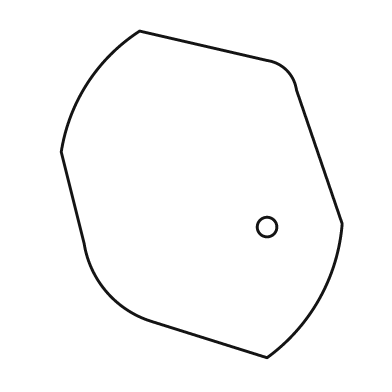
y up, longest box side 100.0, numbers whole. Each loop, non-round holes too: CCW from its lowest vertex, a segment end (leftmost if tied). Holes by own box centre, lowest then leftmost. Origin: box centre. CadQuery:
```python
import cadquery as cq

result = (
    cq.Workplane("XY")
    .moveTo(20.0, -50.0)
    .threePointArc((36.0, -32.0), (43.0, -9.0))
    .lineTo(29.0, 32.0)
    .threePointArc((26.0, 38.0), (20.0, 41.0))
    .lineTo(-19.0, 50.0)
    .threePointArc((-35.0, 34.0), (-43.0, 13.0))
    .lineTo(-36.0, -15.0)
    .threePointArc((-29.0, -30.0), (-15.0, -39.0))
    .close()
    .moveTo(20.0, -10.0)
    .circle(3.0)
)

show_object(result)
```